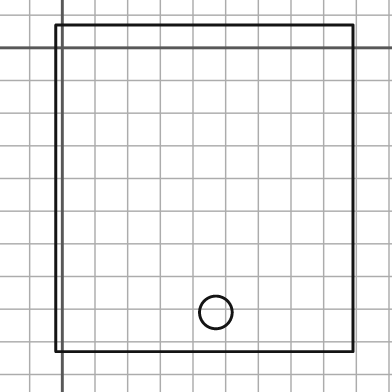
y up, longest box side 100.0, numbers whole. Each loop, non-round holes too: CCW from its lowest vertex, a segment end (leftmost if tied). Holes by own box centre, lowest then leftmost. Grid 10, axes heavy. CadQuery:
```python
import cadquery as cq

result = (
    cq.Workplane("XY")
    .moveTo(-2.0, -93.0)
    .lineTo(89.0, -93.0)
    .lineTo(89.0, 7.0)
    .lineTo(-2.0, 7.0)
    .close()
    .moveTo(47.0, -81.0)
    .circle(5.0)
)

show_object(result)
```